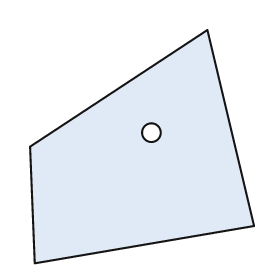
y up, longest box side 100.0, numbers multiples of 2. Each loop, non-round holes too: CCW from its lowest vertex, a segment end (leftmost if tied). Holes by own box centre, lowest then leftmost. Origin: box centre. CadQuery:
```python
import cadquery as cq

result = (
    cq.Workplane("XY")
    .moveTo(-46.0, -50.0)
    .lineTo(48.0, -34.0)
    .lineTo(28.0, 50.0)
    .lineTo(-48.0, 0.0)
    .close()
    .moveTo(4.0, 6.0)
    .circle(4.0)
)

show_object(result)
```